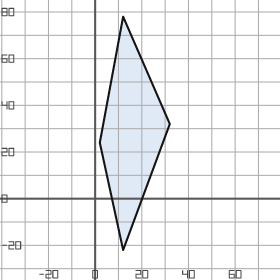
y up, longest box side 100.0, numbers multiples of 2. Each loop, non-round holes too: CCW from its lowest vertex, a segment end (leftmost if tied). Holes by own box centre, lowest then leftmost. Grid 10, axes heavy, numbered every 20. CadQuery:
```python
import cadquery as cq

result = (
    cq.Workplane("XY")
    .moveTo(12.0, -22.0)
    .lineTo(32.0, 32.0)
    .lineTo(12.0, 78.0)
    .lineTo(2.0, 24.0)
    .close()
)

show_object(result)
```